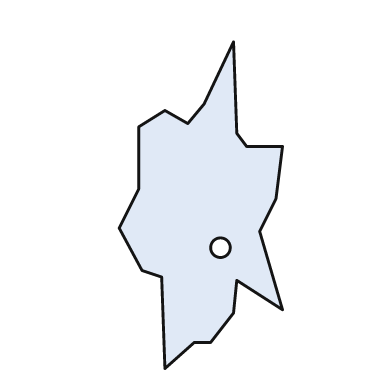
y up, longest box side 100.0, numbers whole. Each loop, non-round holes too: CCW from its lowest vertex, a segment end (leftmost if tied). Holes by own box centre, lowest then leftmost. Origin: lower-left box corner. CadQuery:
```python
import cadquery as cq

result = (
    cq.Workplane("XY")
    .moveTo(14.0, 0.0)
    .lineTo(23.0, 8.0)
    .lineTo(28.0, 8.0)
    .lineTo(35.0, 17.0)
    .lineTo(36.0, 27.0)
    .lineTo(50.0, 18.0)
    .lineTo(43.0, 42.0)
    .lineTo(48.0, 52.0)
    .lineTo(50.0, 68.0)
    .lineTo(39.0, 68.0)
    .lineTo(36.0, 72.0)
    .lineTo(35.0, 100.0)
    .lineTo(26.0, 81.0)
    .lineTo(21.0, 75.0)
    .lineTo(14.0, 79.0)
    .lineTo(6.0, 74.0)
    .lineTo(6.0, 55.0)
    .lineTo(0.0, 43.0)
    .lineTo(7.0, 30.0)
    .lineTo(13.0, 28.0)
    .close()
    .moveTo(31.0, 37.0)
    .circle(3.0)
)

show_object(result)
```